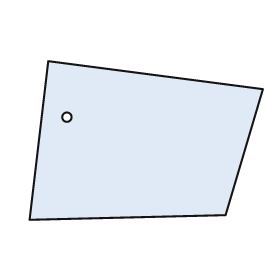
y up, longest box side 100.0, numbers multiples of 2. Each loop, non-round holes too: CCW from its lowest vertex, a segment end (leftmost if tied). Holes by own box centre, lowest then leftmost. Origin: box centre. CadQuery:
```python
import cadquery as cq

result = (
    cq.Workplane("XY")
    .moveTo(-50.0, -34.0)
    .lineTo(34.0, -32.0)
    .lineTo(50.0, 22.0)
    .lineTo(-42.0, 34.0)
    .close()
    .moveTo(-34.0, 10.0)
    .circle(2.0)
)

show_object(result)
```